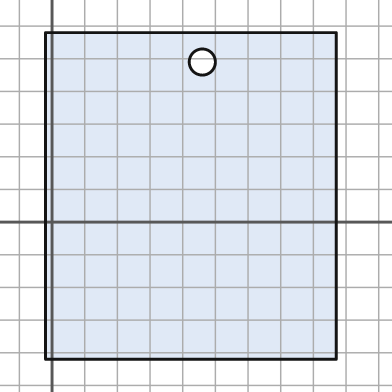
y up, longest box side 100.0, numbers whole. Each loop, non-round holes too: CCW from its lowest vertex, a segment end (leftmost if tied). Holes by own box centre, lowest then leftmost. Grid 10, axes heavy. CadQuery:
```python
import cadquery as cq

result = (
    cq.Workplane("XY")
    .moveTo(-2.0, -42.0)
    .lineTo(87.0, -42.0)
    .lineTo(87.0, 58.0)
    .lineTo(-2.0, 58.0)
    .close()
    .moveTo(46.0, 49.0)
    .circle(4.0)
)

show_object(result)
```